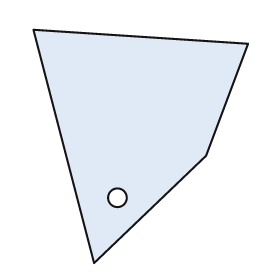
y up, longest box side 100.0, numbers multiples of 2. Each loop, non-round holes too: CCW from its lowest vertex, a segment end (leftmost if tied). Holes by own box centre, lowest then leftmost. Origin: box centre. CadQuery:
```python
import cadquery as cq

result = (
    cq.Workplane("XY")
    .moveTo(-20.0, -50.0)
    .lineTo(28.0, -4.0)
    .lineTo(46.0, 44.0)
    .lineTo(-46.0, 50.0)
    .close()
    .moveTo(-10.0, -22.0)
    .circle(4.0)
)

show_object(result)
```